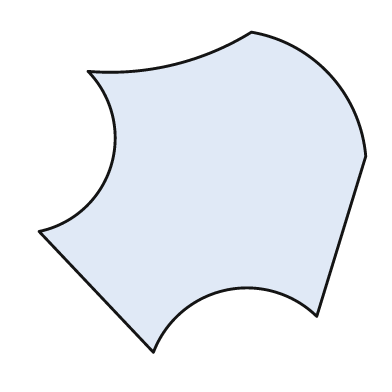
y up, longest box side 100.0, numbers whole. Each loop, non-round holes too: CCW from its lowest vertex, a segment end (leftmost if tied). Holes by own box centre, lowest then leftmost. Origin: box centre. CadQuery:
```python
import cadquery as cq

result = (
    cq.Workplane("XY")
    .moveTo(-15.0, -49.0)
    .threePointArc((7.0, -30.0), (35.0, -38.0))
    .lineTo(50.0, 11.0)
    .threePointArc((39.0, 36.0), (15.0, 49.0))
    .threePointArc((-9.0, 39.0), (-35.0, 37.0))
    .threePointArc((-28.0, 8.0), (-50.0, -12.0))
    .close()
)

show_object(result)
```